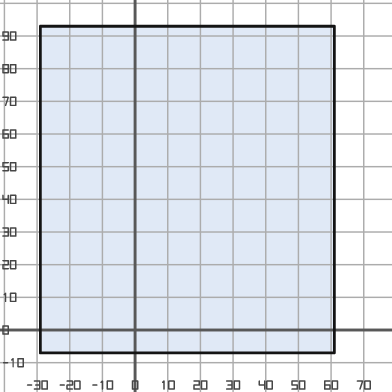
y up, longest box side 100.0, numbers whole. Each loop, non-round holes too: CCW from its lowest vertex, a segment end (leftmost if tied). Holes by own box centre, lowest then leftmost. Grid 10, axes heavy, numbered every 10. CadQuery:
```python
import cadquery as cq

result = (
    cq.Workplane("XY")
    .moveTo(-29.0, -7.0)
    .lineTo(61.0, -7.0)
    .lineTo(61.0, 93.0)
    .lineTo(-29.0, 93.0)
    .close()
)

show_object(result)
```